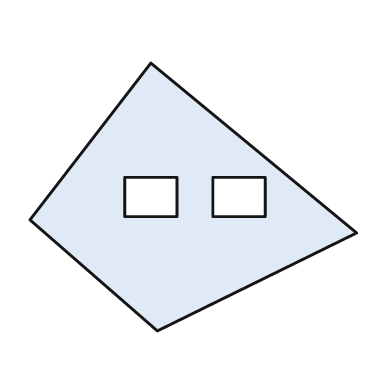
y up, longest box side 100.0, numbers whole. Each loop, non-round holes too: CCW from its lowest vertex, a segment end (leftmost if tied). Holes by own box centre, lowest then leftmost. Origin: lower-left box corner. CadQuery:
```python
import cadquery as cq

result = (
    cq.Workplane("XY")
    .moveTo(39.0, 0.0)
    .lineTo(100.0, 30.0)
    .lineTo(37.0, 82.0)
    .lineTo(0.0, 34.0)
    .close()
    .moveTo(29.0, 35.0)
    .lineTo(45.0, 35.0)
    .lineTo(45.0, 47.0)
    .lineTo(29.0, 47.0)
    .close()
    .moveTo(56.0, 35.0)
    .lineTo(72.0, 35.0)
    .lineTo(72.0, 47.0)
    .lineTo(56.0, 47.0)
    .close()
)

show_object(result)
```